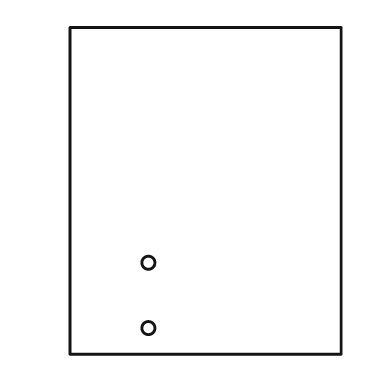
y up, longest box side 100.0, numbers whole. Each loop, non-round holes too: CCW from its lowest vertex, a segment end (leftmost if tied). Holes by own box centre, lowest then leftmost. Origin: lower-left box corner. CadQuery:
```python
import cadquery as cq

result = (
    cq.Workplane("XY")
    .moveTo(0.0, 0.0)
    .lineTo(83.0, 0.0)
    .lineTo(83.0, 100.0)
    .lineTo(0.0, 100.0)
    .close()
    .moveTo(24.0, 8.0)
    .circle(2.0)
    .moveTo(24.0, 28.0)
    .circle(2.0)
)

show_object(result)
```